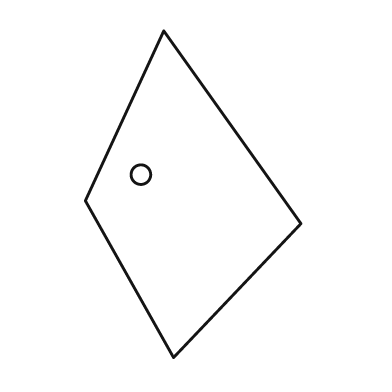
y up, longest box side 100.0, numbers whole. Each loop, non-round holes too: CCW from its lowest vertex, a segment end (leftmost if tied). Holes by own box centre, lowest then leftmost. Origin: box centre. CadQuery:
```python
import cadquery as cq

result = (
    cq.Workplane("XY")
    .moveTo(-6.0, -50.0)
    .lineTo(33.0, -9.0)
    .lineTo(-9.0, 50.0)
    .lineTo(-33.0, -2.0)
    .close()
    .moveTo(-16.0, 6.0)
    .circle(3.0)
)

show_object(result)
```